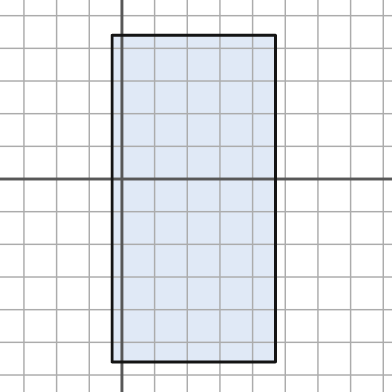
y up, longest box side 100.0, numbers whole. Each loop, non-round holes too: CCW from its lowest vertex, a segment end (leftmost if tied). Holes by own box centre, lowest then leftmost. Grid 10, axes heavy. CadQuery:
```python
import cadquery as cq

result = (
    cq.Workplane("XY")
    .moveTo(-3.0, -56.0)
    .lineTo(47.0, -56.0)
    .lineTo(47.0, 44.0)
    .lineTo(-3.0, 44.0)
    .close()
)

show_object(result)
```